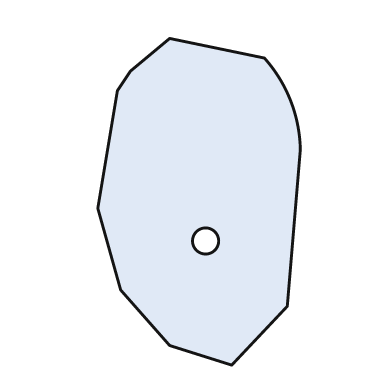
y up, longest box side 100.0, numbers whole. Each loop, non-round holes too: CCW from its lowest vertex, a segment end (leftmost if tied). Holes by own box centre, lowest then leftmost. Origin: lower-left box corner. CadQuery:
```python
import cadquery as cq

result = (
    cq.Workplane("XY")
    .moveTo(41.0, 0.0)
    .lineTo(58.0, 18.0)
    .lineTo(62.0, 66.0)
    .threePointArc((59.0, 81.0), (51.0, 94.0))
    .lineTo(22.0, 100.0)
    .lineTo(10.0, 90.0)
    .lineTo(6.0, 84.0)
    .lineTo(0.0, 48.0)
    .lineTo(7.0, 23.0)
    .lineTo(22.0, 6.0)
    .close()
    .moveTo(33.0, 38.0)
    .circle(4.0)
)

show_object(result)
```